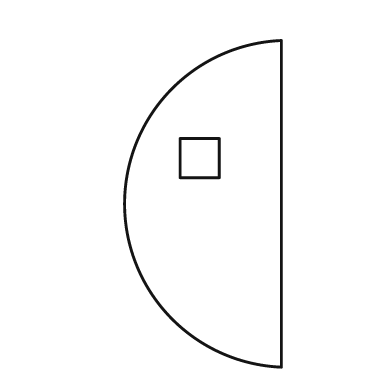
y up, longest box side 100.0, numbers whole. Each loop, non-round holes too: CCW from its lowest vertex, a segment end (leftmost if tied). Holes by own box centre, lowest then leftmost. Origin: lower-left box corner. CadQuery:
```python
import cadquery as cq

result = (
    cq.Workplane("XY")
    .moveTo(48.0, 0.0)
    .lineTo(48.0, 100.0)
    .threePointArc((0.0, 50.0), (48.0, 0.0))
    .close()
    .moveTo(17.0, 58.0)
    .lineTo(29.0, 58.0)
    .lineTo(29.0, 70.0)
    .lineTo(17.0, 70.0)
    .close()
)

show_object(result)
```